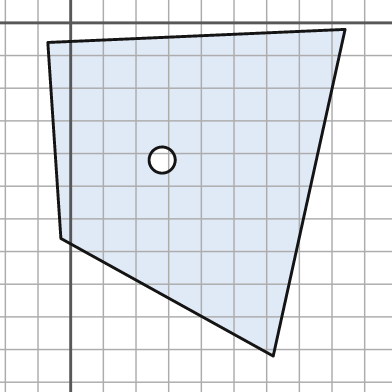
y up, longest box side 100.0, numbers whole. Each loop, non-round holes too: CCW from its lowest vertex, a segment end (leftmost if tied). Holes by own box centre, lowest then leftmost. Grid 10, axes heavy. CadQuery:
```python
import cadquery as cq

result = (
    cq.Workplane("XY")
    .moveTo(62.0, -102.0)
    .lineTo(84.0, -2.0)
    .lineTo(-7.0, -6.0)
    .lineTo(-3.0, -66.0)
    .close()
    .moveTo(28.0, -42.0)
    .circle(4.0)
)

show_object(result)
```